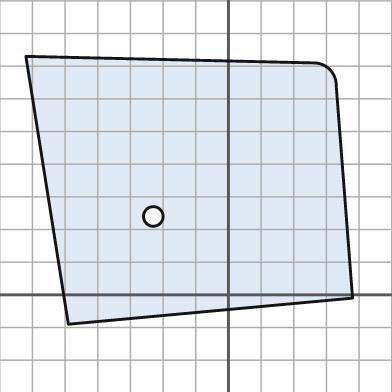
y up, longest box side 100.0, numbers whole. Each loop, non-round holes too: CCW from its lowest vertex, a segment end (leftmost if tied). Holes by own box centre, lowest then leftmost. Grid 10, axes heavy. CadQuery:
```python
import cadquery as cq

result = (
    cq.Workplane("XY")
    .moveTo(-49.0, -9.0)
    .lineTo(38.0, -1.0)
    .lineTo(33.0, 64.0)
    .threePointArc((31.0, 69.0), (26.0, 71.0))
    .lineTo(-62.0, 73.0)
    .close()
    .moveTo(-23.0, 24.0)
    .circle(3.0)
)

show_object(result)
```